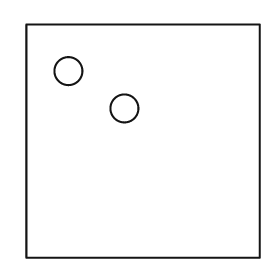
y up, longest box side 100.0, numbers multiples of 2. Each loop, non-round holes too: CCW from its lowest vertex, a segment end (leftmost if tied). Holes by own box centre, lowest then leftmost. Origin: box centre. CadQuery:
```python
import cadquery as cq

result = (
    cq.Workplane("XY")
    .moveTo(-50.0, -50.0)
    .lineTo(50.0, -50.0)
    .lineTo(50.0, 50.0)
    .lineTo(-50.0, 50.0)
    .close()
    .moveTo(-8.0, 14.0)
    .circle(6.0)
    .moveTo(-32.0, 30.0)
    .circle(6.0)
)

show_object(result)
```